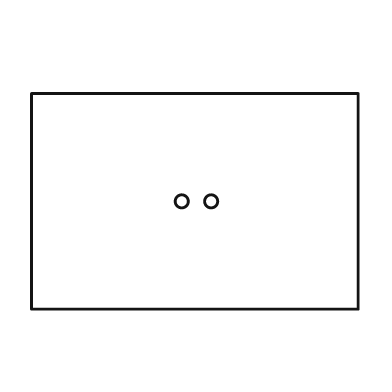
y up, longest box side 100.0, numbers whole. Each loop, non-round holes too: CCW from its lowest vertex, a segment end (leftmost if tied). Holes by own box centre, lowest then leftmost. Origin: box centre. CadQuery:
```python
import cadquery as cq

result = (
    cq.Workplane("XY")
    .moveTo(-50.0, -33.0)
    .lineTo(50.0, -33.0)
    .lineTo(50.0, 33.0)
    .lineTo(-50.0, 33.0)
    .close()
    .moveTo(-4.0, 0.0)
    .circle(2.0)
    .moveTo(5.0, 0.0)
    .circle(2.0)
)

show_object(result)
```